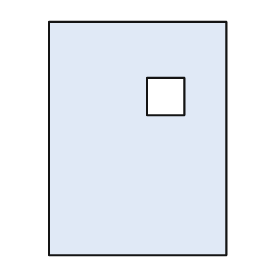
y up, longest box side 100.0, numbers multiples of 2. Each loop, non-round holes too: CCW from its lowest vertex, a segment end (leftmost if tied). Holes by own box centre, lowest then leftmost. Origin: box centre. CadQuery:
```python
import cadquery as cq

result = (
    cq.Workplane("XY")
    .moveTo(-38.0, -50.0)
    .lineTo(38.0, -50.0)
    .lineTo(38.0, 50.0)
    .lineTo(-38.0, 50.0)
    .close()
    .moveTo(4.0, 10.0)
    .lineTo(20.0, 10.0)
    .lineTo(20.0, 26.0)
    .lineTo(4.0, 26.0)
    .close()
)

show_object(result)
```